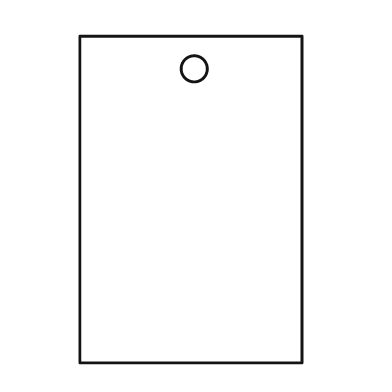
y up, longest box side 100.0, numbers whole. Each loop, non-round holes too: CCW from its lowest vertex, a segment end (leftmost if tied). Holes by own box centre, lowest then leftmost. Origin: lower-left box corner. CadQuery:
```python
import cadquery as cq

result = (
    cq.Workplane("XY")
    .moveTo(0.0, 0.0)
    .lineTo(68.0, 0.0)
    .lineTo(68.0, 100.0)
    .lineTo(0.0, 100.0)
    .close()
    .moveTo(35.0, 90.0)
    .circle(4.0)
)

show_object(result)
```